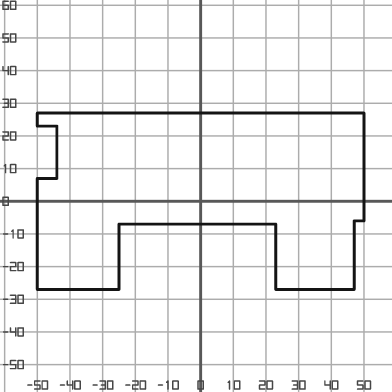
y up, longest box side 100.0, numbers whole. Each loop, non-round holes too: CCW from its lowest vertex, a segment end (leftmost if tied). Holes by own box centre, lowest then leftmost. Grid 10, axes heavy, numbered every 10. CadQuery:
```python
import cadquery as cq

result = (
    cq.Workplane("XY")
    .moveTo(-50.0, -27.0)
    .lineTo(-25.0, -27.0)
    .lineTo(-25.0, -7.0)
    .lineTo(23.0, -7.0)
    .lineTo(23.0, -27.0)
    .lineTo(47.0, -27.0)
    .lineTo(47.0, -6.0)
    .lineTo(50.0, -6.0)
    .lineTo(50.0, 27.0)
    .lineTo(-50.0, 27.0)
    .lineTo(-50.0, 23.0)
    .lineTo(-44.0, 23.0)
    .lineTo(-44.0, 7.0)
    .lineTo(-50.0, 7.0)
    .close()
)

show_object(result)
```